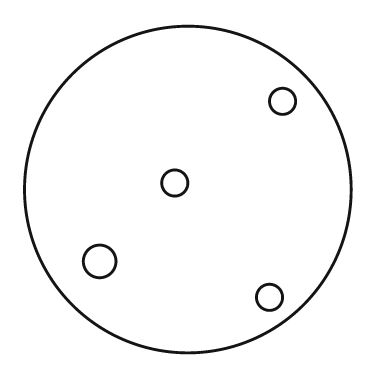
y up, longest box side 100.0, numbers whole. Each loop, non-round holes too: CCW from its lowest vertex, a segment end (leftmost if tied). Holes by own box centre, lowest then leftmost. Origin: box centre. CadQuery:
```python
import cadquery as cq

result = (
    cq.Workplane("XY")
    .moveTo(0.0, 0.0)
    .circle(50.0)
    .moveTo(25.0, -33.0)
    .circle(4.0)
    .moveTo(-27.0, -22.0)
    .circle(5.0)
    .moveTo(-4.0, 2.0)
    .circle(4.0)
    .moveTo(29.0, 27.0)
    .circle(4.0)
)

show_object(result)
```